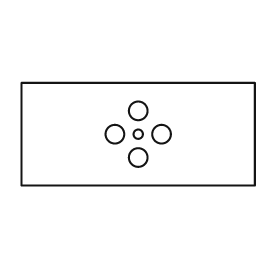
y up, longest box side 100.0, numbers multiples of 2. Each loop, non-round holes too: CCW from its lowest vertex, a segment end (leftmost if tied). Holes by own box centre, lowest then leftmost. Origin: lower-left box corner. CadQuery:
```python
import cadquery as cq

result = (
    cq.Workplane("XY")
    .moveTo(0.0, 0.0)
    .lineTo(100.0, 0.0)
    .lineTo(100.0, 44.0)
    .lineTo(0.0, 44.0)
    .close()
    .moveTo(50.0, 12.0)
    .circle(4.0)
    .moveTo(40.0, 22.0)
    .circle(4.0)
    .moveTo(50.0, 22.0)
    .circle(2.0)
    .moveTo(60.0, 22.0)
    .circle(4.0)
    .moveTo(50.0, 32.0)
    .circle(4.0)
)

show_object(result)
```